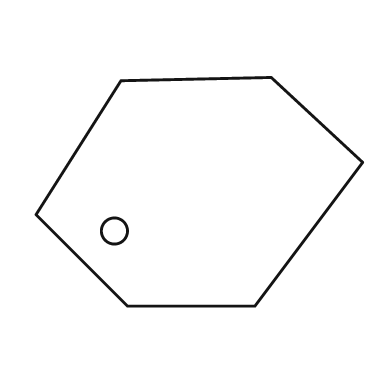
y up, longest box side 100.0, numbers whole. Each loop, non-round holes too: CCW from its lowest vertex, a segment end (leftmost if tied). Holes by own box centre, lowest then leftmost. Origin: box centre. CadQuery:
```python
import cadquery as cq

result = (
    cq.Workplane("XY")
    .moveTo(-22.0, -35.0)
    .lineTo(17.0, -35.0)
    .lineTo(50.0, 9.0)
    .lineTo(22.0, 35.0)
    .lineTo(-24.0, 34.0)
    .lineTo(-50.0, -7.0)
    .close()
    .moveTo(-26.0, -12.0)
    .circle(4.0)
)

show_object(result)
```